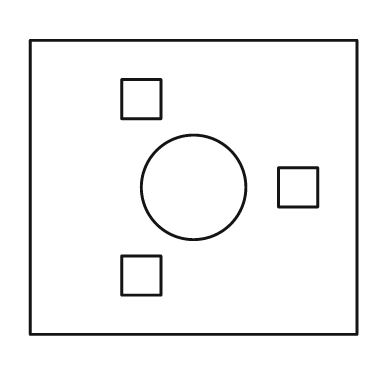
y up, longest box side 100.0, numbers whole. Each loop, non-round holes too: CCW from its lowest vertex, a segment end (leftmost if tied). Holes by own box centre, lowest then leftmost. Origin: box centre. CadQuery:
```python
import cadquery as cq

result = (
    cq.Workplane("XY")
    .moveTo(-50.0, -45.0)
    .lineTo(50.0, -45.0)
    .lineTo(50.0, 45.0)
    .lineTo(-50.0, 45.0)
    .close()
    .moveTo(-22.0, -33.0)
    .lineTo(-10.0, -33.0)
    .lineTo(-10.0, -21.0)
    .lineTo(-22.0, -21.0)
    .close()
    .moveTo(0.0, 0.0)
    .circle(16.0)
    .moveTo(26.0, -6.0)
    .lineTo(38.0, -6.0)
    .lineTo(38.0, 6.0)
    .lineTo(26.0, 6.0)
    .close()
    .moveTo(-22.0, 21.0)
    .lineTo(-10.0, 21.0)
    .lineTo(-10.0, 33.0)
    .lineTo(-22.0, 33.0)
    .close()
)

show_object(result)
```